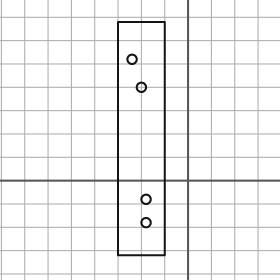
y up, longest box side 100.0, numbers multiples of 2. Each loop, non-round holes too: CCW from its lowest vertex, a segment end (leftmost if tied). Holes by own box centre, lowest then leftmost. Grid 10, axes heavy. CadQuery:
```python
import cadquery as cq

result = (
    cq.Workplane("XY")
    .moveTo(-30.0, -32.0)
    .lineTo(-10.0, -32.0)
    .lineTo(-10.0, 68.0)
    .lineTo(-30.0, 68.0)
    .close()
    .moveTo(-18.0, -18.0)
    .circle(2.0)
    .moveTo(-18.0, -8.0)
    .circle(2.0)
    .moveTo(-20.0, 40.0)
    .circle(2.0)
    .moveTo(-24.0, 52.0)
    .circle(2.0)
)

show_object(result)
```